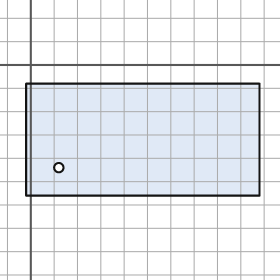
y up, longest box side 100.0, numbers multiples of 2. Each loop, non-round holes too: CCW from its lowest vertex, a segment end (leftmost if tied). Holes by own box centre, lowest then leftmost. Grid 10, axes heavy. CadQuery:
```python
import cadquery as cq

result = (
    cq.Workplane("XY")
    .moveTo(-2.0, -56.0)
    .lineTo(98.0, -56.0)
    .lineTo(98.0, -8.0)
    .lineTo(-2.0, -8.0)
    .close()
    .moveTo(12.0, -44.0)
    .circle(2.0)
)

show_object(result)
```